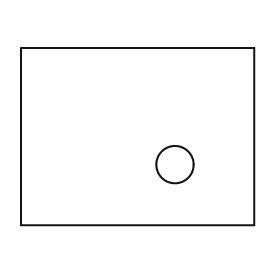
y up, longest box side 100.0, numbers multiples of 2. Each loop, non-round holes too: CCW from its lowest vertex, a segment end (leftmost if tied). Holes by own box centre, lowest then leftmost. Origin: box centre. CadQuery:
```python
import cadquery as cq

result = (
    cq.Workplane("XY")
    .moveTo(-50.0, -38.0)
    .lineTo(50.0, -38.0)
    .lineTo(50.0, 38.0)
    .lineTo(-50.0, 38.0)
    .close()
    .moveTo(16.0, -12.0)
    .circle(8.0)
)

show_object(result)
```